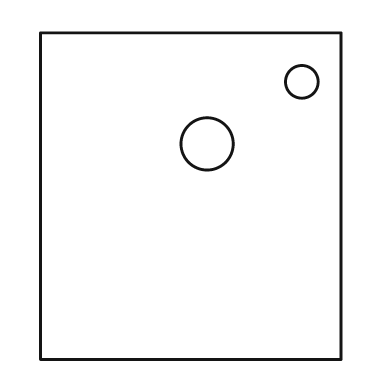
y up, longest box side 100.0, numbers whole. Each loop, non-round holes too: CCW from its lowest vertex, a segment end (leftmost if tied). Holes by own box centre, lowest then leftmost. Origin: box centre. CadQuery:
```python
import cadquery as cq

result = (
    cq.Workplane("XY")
    .moveTo(-46.0, -50.0)
    .lineTo(46.0, -50.0)
    .lineTo(46.0, 50.0)
    .lineTo(-46.0, 50.0)
    .close()
    .moveTo(5.0, 16.0)
    .circle(8.0)
    .moveTo(34.0, 35.0)
    .circle(5.0)
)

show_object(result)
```